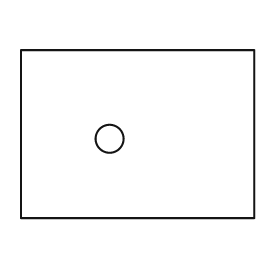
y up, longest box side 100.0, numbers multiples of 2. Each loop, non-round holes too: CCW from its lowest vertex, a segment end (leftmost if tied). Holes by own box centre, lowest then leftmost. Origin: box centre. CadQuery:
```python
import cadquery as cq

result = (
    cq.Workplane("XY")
    .moveTo(-50.0, -36.0)
    .lineTo(50.0, -36.0)
    .lineTo(50.0, 36.0)
    .lineTo(-50.0, 36.0)
    .close()
    .moveTo(-12.0, -2.0)
    .circle(6.0)
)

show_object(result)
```